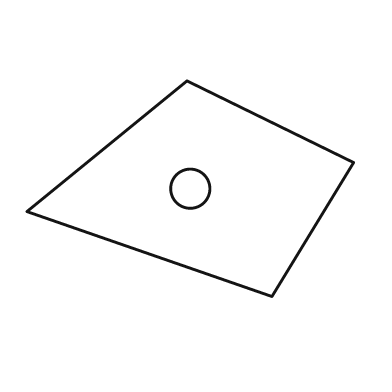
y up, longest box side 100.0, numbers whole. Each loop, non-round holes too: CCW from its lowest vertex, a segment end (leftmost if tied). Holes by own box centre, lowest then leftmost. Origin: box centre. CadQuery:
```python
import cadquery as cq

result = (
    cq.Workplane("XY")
    .moveTo(25.0, -33.0)
    .lineTo(50.0, 8.0)
    .lineTo(-1.0, 33.0)
    .lineTo(-50.0, -7.0)
    .close()
    .moveTo(0.0, 0.0)
    .circle(6.0)
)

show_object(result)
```